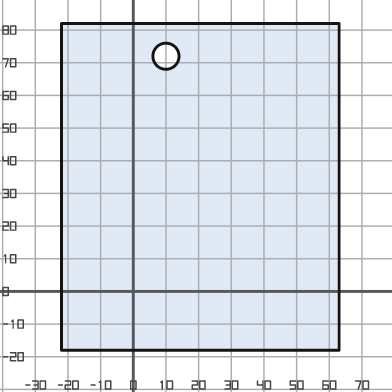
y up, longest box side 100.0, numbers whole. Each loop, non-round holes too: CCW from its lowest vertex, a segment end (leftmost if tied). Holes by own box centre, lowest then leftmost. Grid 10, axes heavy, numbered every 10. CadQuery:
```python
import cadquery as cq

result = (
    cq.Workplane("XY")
    .moveTo(-22.0, -18.0)
    .lineTo(63.0, -18.0)
    .lineTo(63.0, 82.0)
    .lineTo(-22.0, 82.0)
    .close()
    .moveTo(10.0, 72.0)
    .circle(4.0)
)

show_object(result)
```